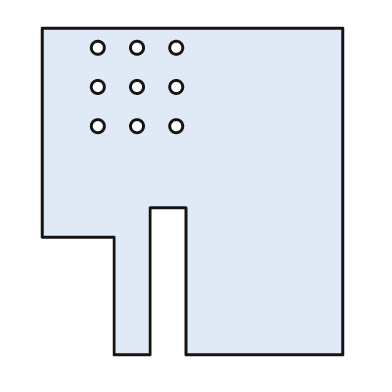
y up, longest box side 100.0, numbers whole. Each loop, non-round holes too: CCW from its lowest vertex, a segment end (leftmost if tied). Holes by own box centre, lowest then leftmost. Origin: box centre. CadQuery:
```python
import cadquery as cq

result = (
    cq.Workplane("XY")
    .moveTo(-24.0, -50.0)
    .lineTo(-13.0, -50.0)
    .lineTo(-13.0, -5.0)
    .lineTo(-2.0, -5.0)
    .lineTo(-2.0, -50.0)
    .lineTo(46.0, -50.0)
    .lineTo(46.0, 50.0)
    .lineTo(-46.0, 50.0)
    .lineTo(-46.0, -14.0)
    .lineTo(-24.0, -14.0)
    .close()
    .moveTo(-29.0, 20.0)
    .circle(2.0)
    .moveTo(-17.0, 20.0)
    .circle(2.0)
    .moveTo(-5.0, 20.0)
    .circle(2.0)
    .moveTo(-29.0, 32.0)
    .circle(2.0)
    .moveTo(-17.0, 32.0)
    .circle(2.0)
    .moveTo(-5.0, 32.0)
    .circle(2.0)
    .moveTo(-29.0, 44.0)
    .circle(2.0)
    .moveTo(-17.0, 44.0)
    .circle(2.0)
    .moveTo(-5.0, 44.0)
    .circle(2.0)
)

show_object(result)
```